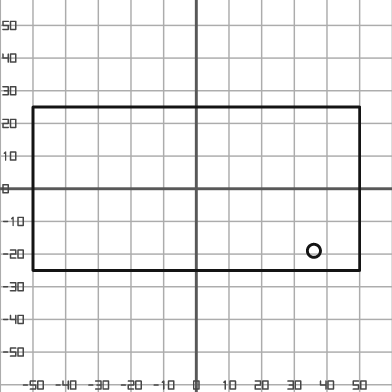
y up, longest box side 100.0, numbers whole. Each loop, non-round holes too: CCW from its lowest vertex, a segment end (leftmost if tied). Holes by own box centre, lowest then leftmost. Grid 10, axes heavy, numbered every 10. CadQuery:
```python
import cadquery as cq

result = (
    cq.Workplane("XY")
    .moveTo(-50.0, -25.0)
    .lineTo(50.0, -25.0)
    .lineTo(50.0, 25.0)
    .lineTo(-50.0, 25.0)
    .close()
    .moveTo(36.0, -19.0)
    .circle(2.0)
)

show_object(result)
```